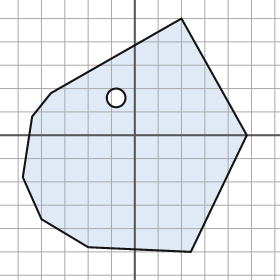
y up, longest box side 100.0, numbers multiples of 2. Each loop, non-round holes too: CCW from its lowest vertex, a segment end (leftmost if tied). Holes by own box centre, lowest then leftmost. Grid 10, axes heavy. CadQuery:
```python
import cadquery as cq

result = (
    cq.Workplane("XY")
    .moveTo(24.0, -50.0)
    .lineTo(48.0, 0.0)
    .lineTo(20.0, 50.0)
    .lineTo(-36.0, 18.0)
    .lineTo(-44.0, 8.0)
    .lineTo(-48.0, -18.0)
    .lineTo(-40.0, -36.0)
    .lineTo(-20.0, -48.0)
    .close()
    .moveTo(-8.0, 16.0)
    .circle(4.0)
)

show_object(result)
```